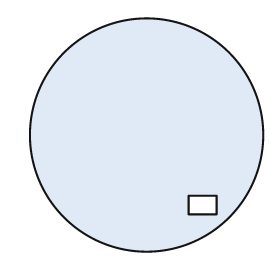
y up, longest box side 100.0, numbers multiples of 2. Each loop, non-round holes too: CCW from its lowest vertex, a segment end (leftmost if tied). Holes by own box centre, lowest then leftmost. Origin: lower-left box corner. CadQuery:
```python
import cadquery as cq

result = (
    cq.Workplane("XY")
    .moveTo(50.0, 50.0)
    .circle(50.0)
    .moveTo(68.0, 16.0)
    .lineTo(80.0, 16.0)
    .lineTo(80.0, 24.0)
    .lineTo(68.0, 24.0)
    .close()
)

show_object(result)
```